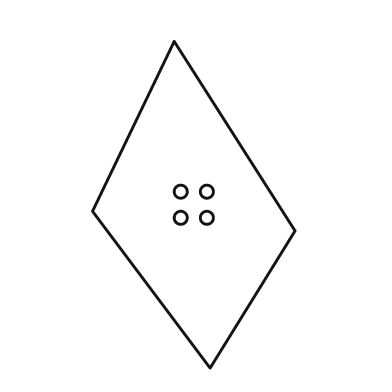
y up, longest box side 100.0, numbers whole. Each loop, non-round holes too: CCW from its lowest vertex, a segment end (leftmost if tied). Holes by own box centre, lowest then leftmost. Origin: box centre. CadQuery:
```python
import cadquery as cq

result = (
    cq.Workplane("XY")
    .moveTo(5.0, -50.0)
    .lineTo(31.0, -8.0)
    .lineTo(-6.0, 50.0)
    .lineTo(-31.0, -2.0)
    .close()
    .moveTo(-4.0, -4.0)
    .circle(2.0)
    .moveTo(4.0, -4.0)
    .circle(2.0)
    .moveTo(-4.0, 4.0)
    .circle(2.0)
    .moveTo(4.0, 4.0)
    .circle(2.0)
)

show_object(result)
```